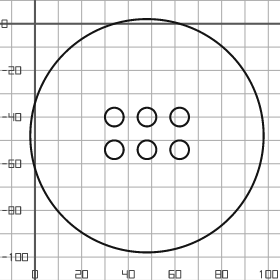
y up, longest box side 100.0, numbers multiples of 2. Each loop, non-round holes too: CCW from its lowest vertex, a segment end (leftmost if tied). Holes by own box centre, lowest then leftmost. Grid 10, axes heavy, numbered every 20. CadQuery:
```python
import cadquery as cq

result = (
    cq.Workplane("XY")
    .moveTo(48.0, -48.0)
    .circle(50.0)
    .moveTo(34.0, -54.0)
    .circle(4.0)
    .moveTo(48.0, -54.0)
    .circle(4.0)
    .moveTo(62.0, -54.0)
    .circle(4.0)
    .moveTo(34.0, -40.0)
    .circle(4.0)
    .moveTo(48.0, -40.0)
    .circle(4.0)
    .moveTo(62.0, -40.0)
    .circle(4.0)
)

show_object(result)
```